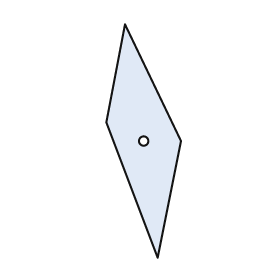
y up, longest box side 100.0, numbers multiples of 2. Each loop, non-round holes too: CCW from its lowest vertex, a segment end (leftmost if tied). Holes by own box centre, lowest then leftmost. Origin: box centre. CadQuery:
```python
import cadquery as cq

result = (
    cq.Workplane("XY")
    .moveTo(6.0, -50.0)
    .lineTo(16.0, 0.0)
    .lineTo(-8.0, 50.0)
    .lineTo(-16.0, 8.0)
    .close()
    .moveTo(0.0, 0.0)
    .circle(2.0)
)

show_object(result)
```